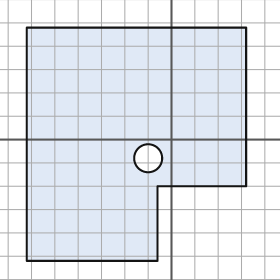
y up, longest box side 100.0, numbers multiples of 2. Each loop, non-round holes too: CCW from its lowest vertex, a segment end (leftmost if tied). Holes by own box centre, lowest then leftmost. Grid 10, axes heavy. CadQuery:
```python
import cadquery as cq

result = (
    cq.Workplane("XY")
    .moveTo(-62.0, -52.0)
    .lineTo(-6.0, -52.0)
    .lineTo(-6.0, -20.0)
    .lineTo(32.0, -20.0)
    .lineTo(32.0, 48.0)
    .lineTo(-62.0, 48.0)
    .close()
    .moveTo(-10.0, -8.0)
    .circle(6.0)
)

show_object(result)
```